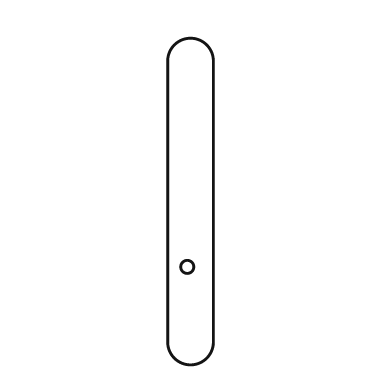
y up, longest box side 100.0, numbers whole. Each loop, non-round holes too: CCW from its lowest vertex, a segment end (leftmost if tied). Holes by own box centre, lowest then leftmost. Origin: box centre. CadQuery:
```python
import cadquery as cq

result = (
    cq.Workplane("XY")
    .moveTo(-7.0, -43.0)
    .threePointArc((0.0, -50.0), (7.0, -43.0))
    .lineTo(7.0, 43.0)
    .threePointArc((0.0, 50.0), (-7.0, 43.0))
    .close()
    .moveTo(-1.0, -20.0)
    .circle(2.0)
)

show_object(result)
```